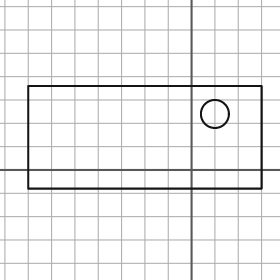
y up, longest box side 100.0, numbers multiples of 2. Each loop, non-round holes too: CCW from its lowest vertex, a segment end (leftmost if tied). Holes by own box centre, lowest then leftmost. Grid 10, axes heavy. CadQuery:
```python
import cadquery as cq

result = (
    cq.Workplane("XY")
    .moveTo(-70.0, -8.0)
    .lineTo(30.0, -8.0)
    .lineTo(30.0, 36.0)
    .lineTo(-70.0, 36.0)
    .close()
    .moveTo(10.0, 24.0)
    .circle(6.0)
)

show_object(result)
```